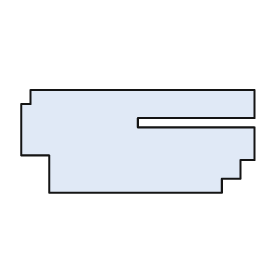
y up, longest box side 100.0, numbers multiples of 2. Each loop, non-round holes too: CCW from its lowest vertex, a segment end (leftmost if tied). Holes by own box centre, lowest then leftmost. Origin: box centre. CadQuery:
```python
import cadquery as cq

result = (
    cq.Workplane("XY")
    .moveTo(-38.0, -22.0)
    .lineTo(36.0, -22.0)
    .lineTo(36.0, -16.0)
    .lineTo(44.0, -16.0)
    .lineTo(44.0, -8.0)
    .lineTo(50.0, -8.0)
    .lineTo(50.0, 6.0)
    .lineTo(0.0, 6.0)
    .lineTo(0.0, 10.0)
    .lineTo(50.0, 10.0)
    .lineTo(50.0, 22.0)
    .lineTo(-46.0, 22.0)
    .lineTo(-46.0, 16.0)
    .lineTo(-50.0, 16.0)
    .lineTo(-50.0, -6.0)
    .lineTo(-38.0, -6.0)
    .close()
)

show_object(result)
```